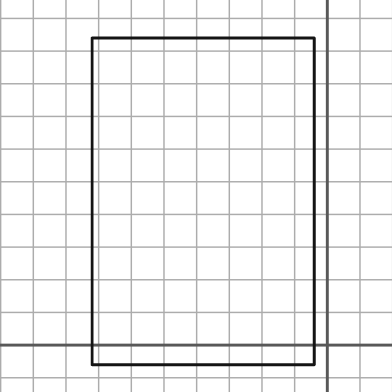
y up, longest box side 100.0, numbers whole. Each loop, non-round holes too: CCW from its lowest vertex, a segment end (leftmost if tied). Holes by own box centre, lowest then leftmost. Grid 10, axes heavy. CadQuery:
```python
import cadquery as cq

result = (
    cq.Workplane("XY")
    .moveTo(-72.0, -6.0)
    .lineTo(-4.0, -6.0)
    .lineTo(-4.0, 94.0)
    .lineTo(-72.0, 94.0)
    .close()
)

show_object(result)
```